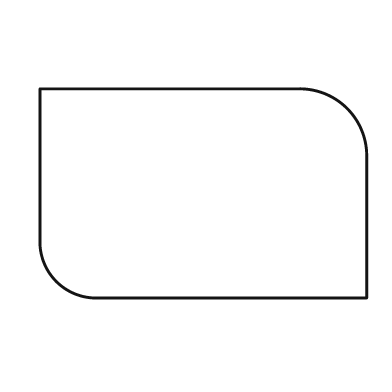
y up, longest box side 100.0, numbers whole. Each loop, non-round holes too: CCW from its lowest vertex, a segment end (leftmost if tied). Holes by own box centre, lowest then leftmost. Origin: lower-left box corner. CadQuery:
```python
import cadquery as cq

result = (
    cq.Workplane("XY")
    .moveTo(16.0, 0.0)
    .lineTo(100.0, 0.0)
    .lineTo(100.0, 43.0)
    .threePointArc((94.0, 58.0), (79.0, 64.0))
    .lineTo(0.0, 64.0)
    .lineTo(0.0, 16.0)
    .threePointArc((5.0, 5.0), (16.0, 0.0))
    .close()
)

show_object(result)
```